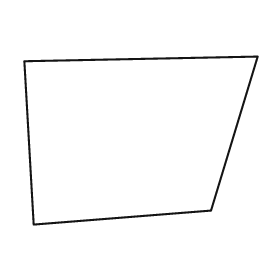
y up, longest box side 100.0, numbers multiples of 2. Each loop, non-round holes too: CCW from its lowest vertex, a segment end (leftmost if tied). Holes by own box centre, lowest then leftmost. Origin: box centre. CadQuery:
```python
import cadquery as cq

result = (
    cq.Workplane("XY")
    .moveTo(-46.0, -36.0)
    .lineTo(30.0, -30.0)
    .lineTo(50.0, 36.0)
    .lineTo(-50.0, 34.0)
    .close()
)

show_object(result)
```